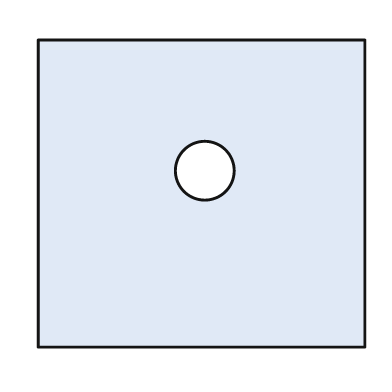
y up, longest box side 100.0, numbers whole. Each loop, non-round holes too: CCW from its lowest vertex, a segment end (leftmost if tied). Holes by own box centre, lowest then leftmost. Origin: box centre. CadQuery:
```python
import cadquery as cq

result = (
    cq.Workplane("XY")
    .moveTo(-50.0, -47.0)
    .lineTo(50.0, -47.0)
    .lineTo(50.0, 47.0)
    .lineTo(-50.0, 47.0)
    .close()
    .moveTo(1.0, 7.0)
    .circle(9.0)
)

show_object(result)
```